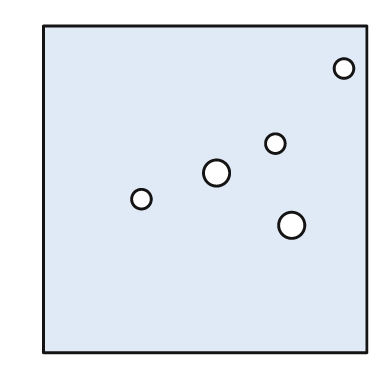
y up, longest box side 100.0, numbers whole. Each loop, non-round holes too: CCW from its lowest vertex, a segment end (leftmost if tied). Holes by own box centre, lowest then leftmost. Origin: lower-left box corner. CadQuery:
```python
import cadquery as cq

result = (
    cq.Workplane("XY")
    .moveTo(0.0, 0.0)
    .lineTo(99.0, 0.0)
    .lineTo(99.0, 100.0)
    .lineTo(0.0, 100.0)
    .close()
    .moveTo(76.0, 39.0)
    .circle(4.0)
    .moveTo(30.0, 47.0)
    .circle(3.0)
    .moveTo(53.0, 55.0)
    .circle(4.0)
    .moveTo(71.0, 64.0)
    .circle(3.0)
    .moveTo(92.0, 87.0)
    .circle(3.0)
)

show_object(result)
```